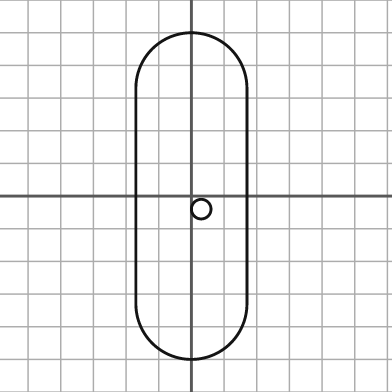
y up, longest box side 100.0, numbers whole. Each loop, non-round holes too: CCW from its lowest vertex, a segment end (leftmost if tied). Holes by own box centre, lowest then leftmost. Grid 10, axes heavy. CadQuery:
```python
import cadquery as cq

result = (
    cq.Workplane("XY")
    .moveTo(-17.0, -33.0)
    .threePointArc((0.0, -50.0), (17.0, -33.0))
    .lineTo(17.0, 33.0)
    .threePointArc((0.0, 50.0), (-17.0, 33.0))
    .close()
    .moveTo(3.0, -4.0)
    .circle(3.0)
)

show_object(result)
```